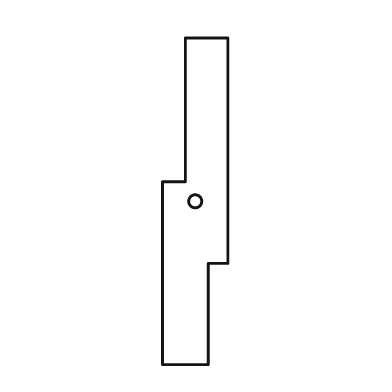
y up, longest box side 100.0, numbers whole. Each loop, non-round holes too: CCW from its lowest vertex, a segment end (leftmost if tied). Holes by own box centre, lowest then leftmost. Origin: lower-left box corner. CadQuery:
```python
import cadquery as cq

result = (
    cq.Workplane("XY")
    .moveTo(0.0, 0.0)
    .lineTo(14.0, 0.0)
    .lineTo(14.0, 31.0)
    .lineTo(20.0, 31.0)
    .lineTo(20.0, 100.0)
    .lineTo(7.0, 100.0)
    .lineTo(7.0, 56.0)
    .lineTo(0.0, 56.0)
    .close()
    .moveTo(10.0, 50.0)
    .circle(2.0)
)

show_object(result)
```